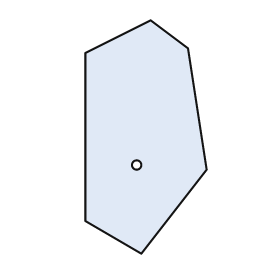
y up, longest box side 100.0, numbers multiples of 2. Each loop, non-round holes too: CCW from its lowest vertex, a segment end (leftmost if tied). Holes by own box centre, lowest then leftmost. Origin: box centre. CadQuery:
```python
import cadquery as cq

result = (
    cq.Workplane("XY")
    .moveTo(-2.0, -50.0)
    .lineTo(26.0, -14.0)
    .lineTo(18.0, 38.0)
    .lineTo(2.0, 50.0)
    .lineTo(-26.0, 36.0)
    .lineTo(-26.0, -36.0)
    .close()
    .moveTo(-4.0, -12.0)
    .circle(2.0)
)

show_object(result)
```